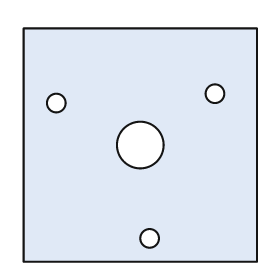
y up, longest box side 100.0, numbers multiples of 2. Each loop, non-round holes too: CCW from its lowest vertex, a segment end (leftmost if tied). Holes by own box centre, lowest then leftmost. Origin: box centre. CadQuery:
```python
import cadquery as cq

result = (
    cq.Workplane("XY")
    .moveTo(-50.0, -50.0)
    .lineTo(50.0, -50.0)
    .lineTo(50.0, 50.0)
    .lineTo(-50.0, 50.0)
    .close()
    .moveTo(4.0, -40.0)
    .circle(4.0)
    .moveTo(0.0, 0.0)
    .circle(10.0)
    .moveTo(-36.0, 18.0)
    .circle(4.0)
    .moveTo(32.0, 22.0)
    .circle(4.0)
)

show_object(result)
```